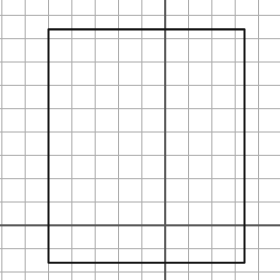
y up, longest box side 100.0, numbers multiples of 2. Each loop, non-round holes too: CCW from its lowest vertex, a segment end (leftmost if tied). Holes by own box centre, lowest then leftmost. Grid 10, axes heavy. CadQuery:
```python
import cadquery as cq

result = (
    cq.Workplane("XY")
    .moveTo(-50.0, -16.0)
    .lineTo(34.0, -16.0)
    .lineTo(34.0, 84.0)
    .lineTo(-50.0, 84.0)
    .close()
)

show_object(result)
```